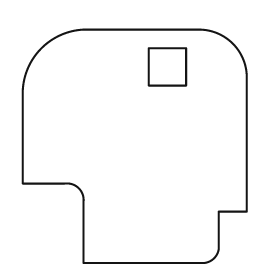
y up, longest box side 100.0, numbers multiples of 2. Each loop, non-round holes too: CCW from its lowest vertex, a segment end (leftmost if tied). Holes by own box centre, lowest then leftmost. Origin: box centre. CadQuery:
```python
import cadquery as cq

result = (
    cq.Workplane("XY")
    .moveTo(-22.0, -50.0)
    .lineTo(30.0, -50.0)
    .threePointArc((34.0, -48.0), (36.0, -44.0))
    .lineTo(36.0, -28.0)
    .lineTo(48.0, -28.0)
    .lineTo(48.0, 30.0)
    .threePointArc((42.0, 44.0), (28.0, 50.0))
    .lineTo(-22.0, 50.0)
    .threePointArc((-40.0, 42.0), (-48.0, 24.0))
    .lineTo(-48.0, -16.0)
    .lineTo(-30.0, -16.0)
    .threePointArc((-24.0, -18.0), (-22.0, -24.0))
    .close()
    .moveTo(6.0, 26.0)
    .lineTo(22.0, 26.0)
    .lineTo(22.0, 42.0)
    .lineTo(6.0, 42.0)
    .close()
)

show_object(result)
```